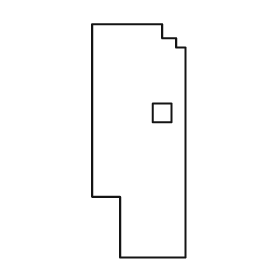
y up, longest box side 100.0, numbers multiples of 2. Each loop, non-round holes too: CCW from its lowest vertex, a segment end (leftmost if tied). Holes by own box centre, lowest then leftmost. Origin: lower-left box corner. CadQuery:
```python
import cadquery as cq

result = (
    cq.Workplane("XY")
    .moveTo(12.0, 0.0)
    .lineTo(40.0, 0.0)
    .lineTo(40.0, 90.0)
    .lineTo(36.0, 90.0)
    .lineTo(36.0, 94.0)
    .lineTo(30.0, 94.0)
    .lineTo(30.0, 100.0)
    .lineTo(0.0, 100.0)
    .lineTo(0.0, 26.0)
    .lineTo(12.0, 26.0)
    .close()
    .moveTo(26.0, 58.0)
    .lineTo(34.0, 58.0)
    .lineTo(34.0, 66.0)
    .lineTo(26.0, 66.0)
    .close()
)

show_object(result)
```